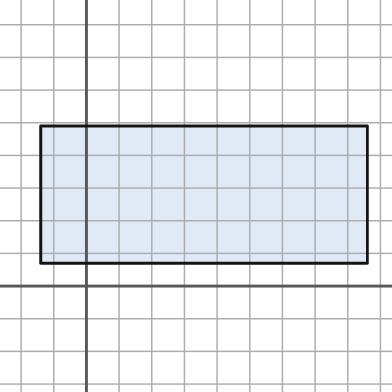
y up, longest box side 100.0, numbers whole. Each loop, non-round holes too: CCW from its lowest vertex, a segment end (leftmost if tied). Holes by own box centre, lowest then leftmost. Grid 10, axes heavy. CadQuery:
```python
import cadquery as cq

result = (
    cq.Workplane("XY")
    .moveTo(-14.0, 7.0)
    .lineTo(86.0, 7.0)
    .lineTo(86.0, 49.0)
    .lineTo(-14.0, 49.0)
    .close()
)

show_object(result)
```